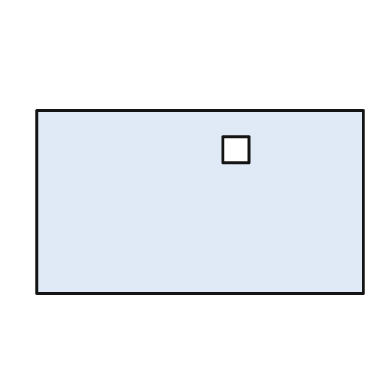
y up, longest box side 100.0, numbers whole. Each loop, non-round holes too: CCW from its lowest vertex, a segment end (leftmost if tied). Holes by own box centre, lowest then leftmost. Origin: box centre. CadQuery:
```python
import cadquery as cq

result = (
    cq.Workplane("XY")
    .moveTo(-50.0, -28.0)
    .lineTo(50.0, -28.0)
    .lineTo(50.0, 28.0)
    .lineTo(-50.0, 28.0)
    .close()
    .moveTo(7.0, 12.0)
    .lineTo(15.0, 12.0)
    .lineTo(15.0, 20.0)
    .lineTo(7.0, 20.0)
    .close()
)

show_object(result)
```